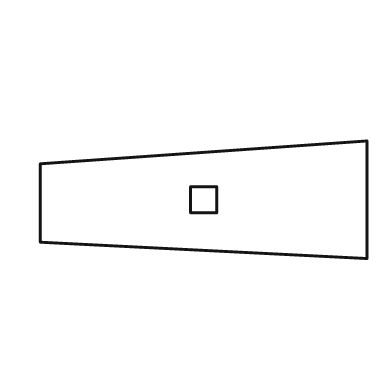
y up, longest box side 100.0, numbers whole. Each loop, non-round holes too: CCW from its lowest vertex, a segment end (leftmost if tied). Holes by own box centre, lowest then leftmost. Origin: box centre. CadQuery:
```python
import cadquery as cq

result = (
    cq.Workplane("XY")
    .moveTo(50.0, -18.0)
    .lineTo(50.0, 18.0)
    .lineTo(-50.0, 11.0)
    .lineTo(-50.0, -13.0)
    .close()
    .moveTo(-4.0, -4.0)
    .lineTo(4.0, -4.0)
    .lineTo(4.0, 4.0)
    .lineTo(-4.0, 4.0)
    .close()
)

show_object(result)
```